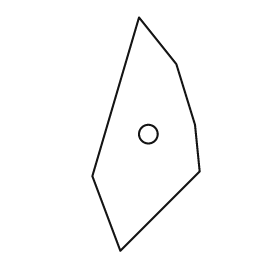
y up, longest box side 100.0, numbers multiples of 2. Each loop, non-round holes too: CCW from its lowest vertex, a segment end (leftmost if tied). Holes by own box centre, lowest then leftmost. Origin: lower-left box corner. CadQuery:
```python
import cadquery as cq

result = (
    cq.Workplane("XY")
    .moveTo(12.0, 0.0)
    .lineTo(46.0, 34.0)
    .lineTo(44.0, 54.0)
    .lineTo(36.0, 80.0)
    .lineTo(20.0, 100.0)
    .lineTo(0.0, 32.0)
    .close()
    .moveTo(24.0, 50.0)
    .circle(4.0)
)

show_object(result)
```